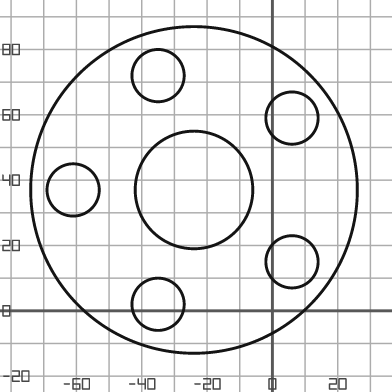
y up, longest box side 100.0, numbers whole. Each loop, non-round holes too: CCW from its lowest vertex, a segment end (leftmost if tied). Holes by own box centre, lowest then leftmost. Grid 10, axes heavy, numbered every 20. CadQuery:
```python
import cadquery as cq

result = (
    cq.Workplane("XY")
    .moveTo(-24.0, 37.0)
    .circle(50.0)
    .moveTo(-35.0, 2.0)
    .circle(8.0)
    .moveTo(6.0, 15.0)
    .circle(8.0)
    .moveTo(-61.0, 37.0)
    .circle(8.0)
    .moveTo(-24.0, 37.0)
    .circle(18.0)
    .moveTo(6.0, 59.0)
    .circle(8.0)
    .moveTo(-35.0, 72.0)
    .circle(8.0)
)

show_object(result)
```